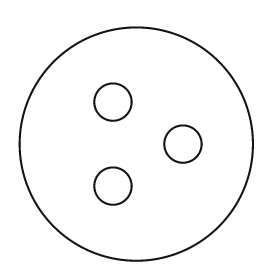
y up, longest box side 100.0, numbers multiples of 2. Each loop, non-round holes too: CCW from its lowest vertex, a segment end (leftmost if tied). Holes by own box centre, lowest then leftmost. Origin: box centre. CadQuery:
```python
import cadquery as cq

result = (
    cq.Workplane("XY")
    .moveTo(0.0, 0.0)
    .circle(50.0)
    .moveTo(-10.0, -18.0)
    .circle(8.0)
    .moveTo(20.0, 0.0)
    .circle(8.0)
    .moveTo(-10.0, 18.0)
    .circle(8.0)
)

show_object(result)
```